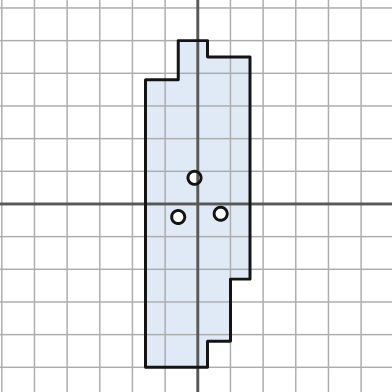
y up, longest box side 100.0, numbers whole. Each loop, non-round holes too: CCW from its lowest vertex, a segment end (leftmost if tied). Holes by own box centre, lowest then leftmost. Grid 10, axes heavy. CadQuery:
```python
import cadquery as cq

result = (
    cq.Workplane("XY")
    .moveTo(-16.0, -50.0)
    .lineTo(3.0, -50.0)
    .lineTo(3.0, -42.0)
    .lineTo(10.0, -42.0)
    .lineTo(10.0, -23.0)
    .lineTo(16.0, -23.0)
    .lineTo(16.0, 45.0)
    .lineTo(3.0, 45.0)
    .lineTo(3.0, 50.0)
    .lineTo(-6.0, 50.0)
    .lineTo(-6.0, 38.0)
    .lineTo(-16.0, 38.0)
    .close()
    .moveTo(-6.0, -4.0)
    .circle(2.0)
    .moveTo(7.0, -3.0)
    .circle(2.0)
    .moveTo(-1.0, 8.0)
    .circle(2.0)
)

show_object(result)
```